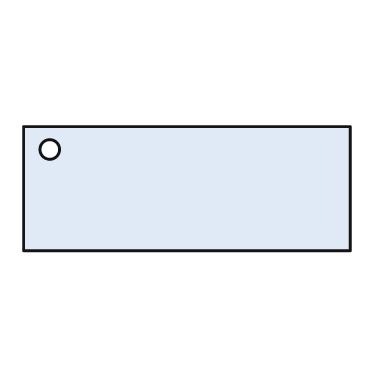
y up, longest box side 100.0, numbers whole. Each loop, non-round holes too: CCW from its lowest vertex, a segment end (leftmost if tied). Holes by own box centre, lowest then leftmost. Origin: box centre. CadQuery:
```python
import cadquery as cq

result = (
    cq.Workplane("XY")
    .moveTo(-50.0, -19.0)
    .lineTo(50.0, -19.0)
    .lineTo(50.0, 19.0)
    .lineTo(-50.0, 19.0)
    .close()
    .moveTo(-42.0, 12.0)
    .circle(3.0)
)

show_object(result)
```